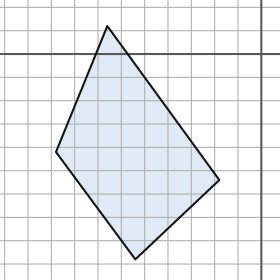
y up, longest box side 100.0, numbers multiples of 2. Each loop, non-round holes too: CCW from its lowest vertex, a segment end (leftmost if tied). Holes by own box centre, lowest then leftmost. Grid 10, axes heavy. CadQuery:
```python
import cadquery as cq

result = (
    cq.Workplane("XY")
    .moveTo(-54.0, -88.0)
    .lineTo(-18.0, -54.0)
    .lineTo(-66.0, 12.0)
    .lineTo(-88.0, -42.0)
    .close()
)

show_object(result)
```